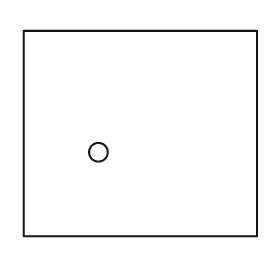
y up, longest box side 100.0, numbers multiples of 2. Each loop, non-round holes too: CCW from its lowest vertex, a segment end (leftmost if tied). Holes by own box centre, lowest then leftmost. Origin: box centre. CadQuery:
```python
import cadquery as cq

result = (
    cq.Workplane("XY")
    .moveTo(-50.0, -44.0)
    .lineTo(50.0, -44.0)
    .lineTo(50.0, 44.0)
    .lineTo(-50.0, 44.0)
    .close()
    .moveTo(-18.0, -8.0)
    .circle(4.0)
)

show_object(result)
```